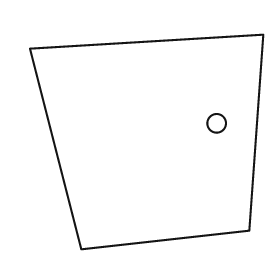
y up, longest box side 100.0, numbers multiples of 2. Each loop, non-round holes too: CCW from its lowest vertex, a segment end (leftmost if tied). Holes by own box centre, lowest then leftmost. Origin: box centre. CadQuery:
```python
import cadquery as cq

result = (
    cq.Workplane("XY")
    .moveTo(-28.0, -46.0)
    .lineTo(44.0, -38.0)
    .lineTo(50.0, 46.0)
    .lineTo(-50.0, 40.0)
    .close()
    .moveTo(30.0, 8.0)
    .circle(4.0)
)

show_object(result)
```